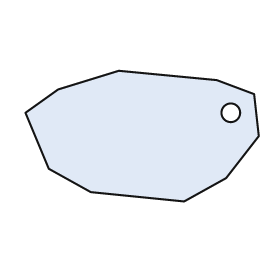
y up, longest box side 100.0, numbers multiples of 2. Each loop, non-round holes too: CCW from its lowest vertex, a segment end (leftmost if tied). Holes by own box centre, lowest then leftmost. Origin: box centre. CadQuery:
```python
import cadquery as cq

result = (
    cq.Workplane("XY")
    .moveTo(18.0, -28.0)
    .lineTo(36.0, -18.0)
    .lineTo(50.0, 0.0)
    .lineTo(48.0, 18.0)
    .lineTo(32.0, 24.0)
    .lineTo(-10.0, 28.0)
    .lineTo(-36.0, 20.0)
    .lineTo(-50.0, 10.0)
    .lineTo(-40.0, -14.0)
    .lineTo(-22.0, -24.0)
    .close()
    .moveTo(38.0, 10.0)
    .circle(4.0)
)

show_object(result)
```